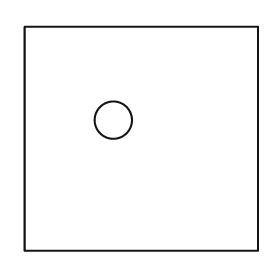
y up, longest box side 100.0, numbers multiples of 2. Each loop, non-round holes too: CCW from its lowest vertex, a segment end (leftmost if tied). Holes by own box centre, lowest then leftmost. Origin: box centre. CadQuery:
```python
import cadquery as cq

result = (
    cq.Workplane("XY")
    .moveTo(-50.0, -48.0)
    .lineTo(50.0, -48.0)
    .lineTo(50.0, 48.0)
    .lineTo(-50.0, 48.0)
    .close()
    .moveTo(-12.0, 8.0)
    .circle(8.0)
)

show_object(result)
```